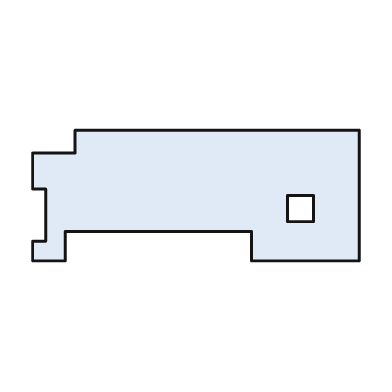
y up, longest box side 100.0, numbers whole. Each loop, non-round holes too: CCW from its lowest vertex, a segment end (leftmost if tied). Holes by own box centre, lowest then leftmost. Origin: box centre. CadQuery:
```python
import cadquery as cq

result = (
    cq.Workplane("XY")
    .moveTo(-50.0, -20.0)
    .lineTo(-40.0, -20.0)
    .lineTo(-40.0, -11.0)
    .lineTo(17.0, -11.0)
    .lineTo(17.0, -20.0)
    .lineTo(50.0, -20.0)
    .lineTo(50.0, 20.0)
    .lineTo(-37.0, 20.0)
    .lineTo(-37.0, 13.0)
    .lineTo(-50.0, 13.0)
    .lineTo(-50.0, 2.0)
    .lineTo(-46.0, 2.0)
    .lineTo(-46.0, -14.0)
    .lineTo(-50.0, -14.0)
    .close()
    .moveTo(28.0, -8.0)
    .lineTo(36.0, -8.0)
    .lineTo(36.0, 0.0)
    .lineTo(28.0, 0.0)
    .close()
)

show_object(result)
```